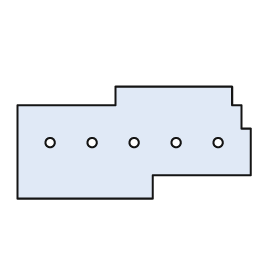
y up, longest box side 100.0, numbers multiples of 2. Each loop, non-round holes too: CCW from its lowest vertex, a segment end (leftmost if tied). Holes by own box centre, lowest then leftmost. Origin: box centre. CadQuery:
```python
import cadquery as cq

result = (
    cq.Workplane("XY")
    .moveTo(-50.0, -24.0)
    .lineTo(8.0, -24.0)
    .lineTo(8.0, -14.0)
    .lineTo(50.0, -14.0)
    .lineTo(50.0, 6.0)
    .lineTo(46.0, 6.0)
    .lineTo(46.0, 16.0)
    .lineTo(42.0, 16.0)
    .lineTo(42.0, 24.0)
    .lineTo(-8.0, 24.0)
    .lineTo(-8.0, 16.0)
    .lineTo(-50.0, 16.0)
    .close()
    .moveTo(-36.0, 0.0)
    .circle(2.0)
    .moveTo(-18.0, 0.0)
    .circle(2.0)
    .moveTo(0.0, 0.0)
    .circle(2.0)
    .moveTo(18.0, 0.0)
    .circle(2.0)
    .moveTo(36.0, 0.0)
    .circle(2.0)
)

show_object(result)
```